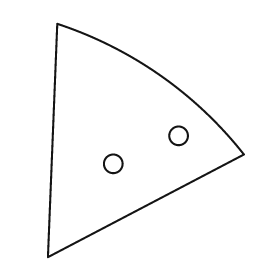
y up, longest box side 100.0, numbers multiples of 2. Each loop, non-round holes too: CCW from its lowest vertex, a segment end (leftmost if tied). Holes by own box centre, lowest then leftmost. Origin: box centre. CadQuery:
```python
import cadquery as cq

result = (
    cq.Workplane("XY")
    .moveTo(-42.0, -50.0)
    .lineTo(42.0, -6.0)
    .threePointArc((6.0, 28.0), (-38.0, 50.0))
    .close()
    .moveTo(-14.0, -10.0)
    .circle(4.0)
    .moveTo(14.0, 2.0)
    .circle(4.0)
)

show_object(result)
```